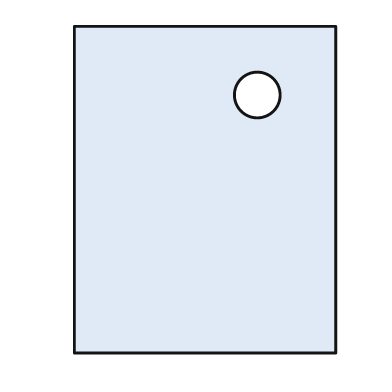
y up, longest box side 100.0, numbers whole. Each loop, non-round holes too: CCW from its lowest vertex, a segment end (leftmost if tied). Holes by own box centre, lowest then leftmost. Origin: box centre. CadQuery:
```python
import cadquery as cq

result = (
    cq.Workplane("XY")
    .moveTo(-40.0, -50.0)
    .lineTo(40.0, -50.0)
    .lineTo(40.0, 50.0)
    .lineTo(-40.0, 50.0)
    .close()
    .moveTo(16.0, 29.0)
    .circle(7.0)
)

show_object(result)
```